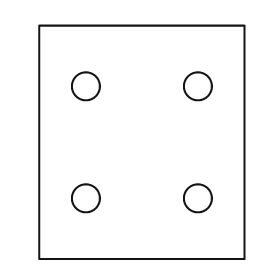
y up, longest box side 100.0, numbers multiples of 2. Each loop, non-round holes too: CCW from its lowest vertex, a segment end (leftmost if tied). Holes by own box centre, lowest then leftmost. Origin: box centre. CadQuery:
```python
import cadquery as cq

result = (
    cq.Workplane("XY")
    .moveTo(-44.0, -50.0)
    .lineTo(44.0, -50.0)
    .lineTo(44.0, 50.0)
    .lineTo(-44.0, 50.0)
    .close()
    .moveTo(-24.0, -24.0)
    .circle(6.0)
    .moveTo(24.0, -24.0)
    .circle(6.0)
    .moveTo(-24.0, 24.0)
    .circle(6.0)
    .moveTo(24.0, 24.0)
    .circle(6.0)
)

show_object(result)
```